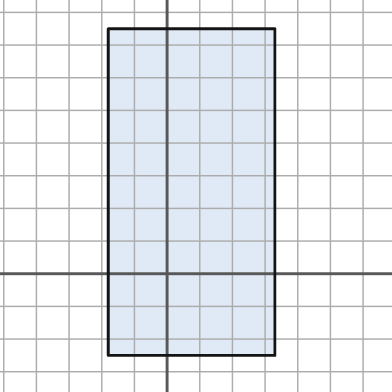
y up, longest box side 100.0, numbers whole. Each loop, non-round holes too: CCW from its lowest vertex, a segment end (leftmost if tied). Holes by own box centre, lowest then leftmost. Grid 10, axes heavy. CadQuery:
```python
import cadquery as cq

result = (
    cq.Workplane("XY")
    .moveTo(-18.0, -25.0)
    .lineTo(33.0, -25.0)
    .lineTo(33.0, 75.0)
    .lineTo(-18.0, 75.0)
    .close()
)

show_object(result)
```